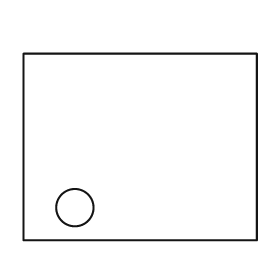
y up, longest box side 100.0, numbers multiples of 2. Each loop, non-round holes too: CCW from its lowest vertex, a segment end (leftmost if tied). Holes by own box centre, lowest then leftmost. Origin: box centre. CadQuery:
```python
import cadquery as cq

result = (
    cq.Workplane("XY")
    .moveTo(-50.0, -40.0)
    .lineTo(50.0, -40.0)
    .lineTo(50.0, 40.0)
    .lineTo(-50.0, 40.0)
    .close()
    .moveTo(-28.0, -26.0)
    .circle(8.0)
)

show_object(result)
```